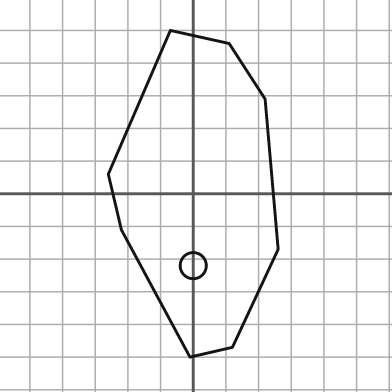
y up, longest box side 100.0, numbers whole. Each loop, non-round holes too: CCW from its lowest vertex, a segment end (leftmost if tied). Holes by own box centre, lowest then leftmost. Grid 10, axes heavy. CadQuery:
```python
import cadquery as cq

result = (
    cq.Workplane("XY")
    .moveTo(-1.0, -50.0)
    .lineTo(12.0, -47.0)
    .lineTo(26.0, -17.0)
    .lineTo(22.0, 29.0)
    .lineTo(11.0, 46.0)
    .lineTo(-7.0, 50.0)
    .lineTo(-26.0, 6.0)
    .lineTo(-22.0, -11.0)
    .close()
    .moveTo(0.0, -22.0)
    .circle(4.0)
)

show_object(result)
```